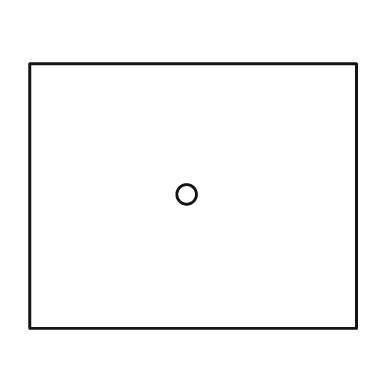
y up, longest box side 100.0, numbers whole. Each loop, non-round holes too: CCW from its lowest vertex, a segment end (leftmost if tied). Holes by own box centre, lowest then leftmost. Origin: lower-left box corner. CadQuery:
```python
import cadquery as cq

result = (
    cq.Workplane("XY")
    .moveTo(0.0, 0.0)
    .lineTo(100.0, 0.0)
    .lineTo(100.0, 81.0)
    .lineTo(0.0, 81.0)
    .close()
    .moveTo(48.0, 41.0)
    .circle(3.0)
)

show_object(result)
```